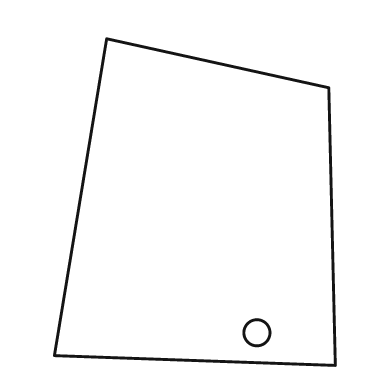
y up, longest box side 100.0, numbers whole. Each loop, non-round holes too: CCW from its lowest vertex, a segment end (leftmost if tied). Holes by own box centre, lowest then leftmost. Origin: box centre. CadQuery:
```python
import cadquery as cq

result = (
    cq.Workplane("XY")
    .moveTo(43.0, -50.0)
    .lineTo(41.0, 35.0)
    .lineTo(-27.0, 50.0)
    .lineTo(-43.0, -47.0)
    .close()
    .moveTo(19.0, -40.0)
    .circle(4.0)
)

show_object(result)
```